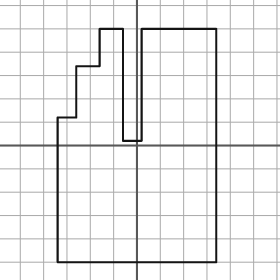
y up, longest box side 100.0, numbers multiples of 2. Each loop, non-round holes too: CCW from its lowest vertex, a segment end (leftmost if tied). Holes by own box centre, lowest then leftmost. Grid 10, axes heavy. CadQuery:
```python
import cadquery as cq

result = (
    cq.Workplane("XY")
    .moveTo(-34.0, -50.0)
    .lineTo(34.0, -50.0)
    .lineTo(34.0, 50.0)
    .lineTo(2.0, 50.0)
    .lineTo(2.0, 2.0)
    .lineTo(-6.0, 2.0)
    .lineTo(-6.0, 50.0)
    .lineTo(-16.0, 50.0)
    .lineTo(-16.0, 34.0)
    .lineTo(-26.0, 34.0)
    .lineTo(-26.0, 12.0)
    .lineTo(-34.0, 12.0)
    .close()
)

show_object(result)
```